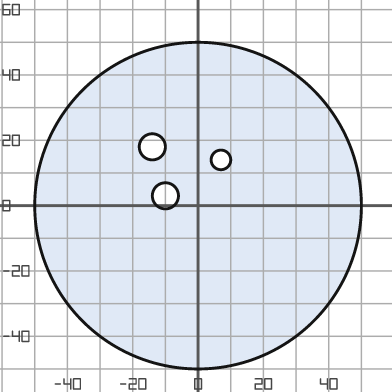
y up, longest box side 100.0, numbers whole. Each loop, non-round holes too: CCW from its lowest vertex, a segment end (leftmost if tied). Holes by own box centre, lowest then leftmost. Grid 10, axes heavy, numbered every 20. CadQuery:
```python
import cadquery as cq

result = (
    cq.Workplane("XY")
    .moveTo(0.0, 0.0)
    .circle(50.0)
    .moveTo(-10.0, 3.0)
    .circle(4.0)
    .moveTo(7.0, 14.0)
    .circle(3.0)
    .moveTo(-14.0, 18.0)
    .circle(4.0)
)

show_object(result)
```